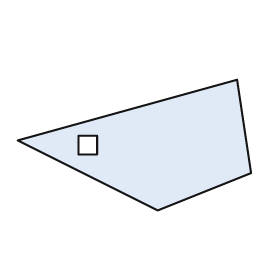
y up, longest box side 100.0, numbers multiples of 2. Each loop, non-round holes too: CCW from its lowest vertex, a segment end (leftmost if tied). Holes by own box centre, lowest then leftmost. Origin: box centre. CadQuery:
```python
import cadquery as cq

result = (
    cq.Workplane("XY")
    .moveTo(10.0, -28.0)
    .lineTo(50.0, -12.0)
    .lineTo(44.0, 28.0)
    .lineTo(-50.0, 2.0)
    .close()
    .moveTo(-24.0, -4.0)
    .lineTo(-16.0, -4.0)
    .lineTo(-16.0, 4.0)
    .lineTo(-24.0, 4.0)
    .close()
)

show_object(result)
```